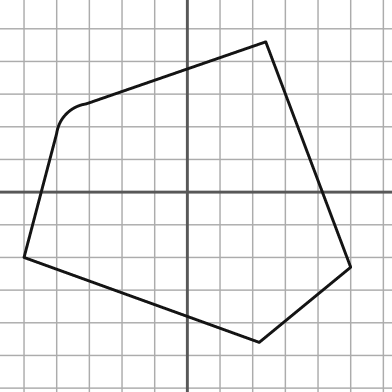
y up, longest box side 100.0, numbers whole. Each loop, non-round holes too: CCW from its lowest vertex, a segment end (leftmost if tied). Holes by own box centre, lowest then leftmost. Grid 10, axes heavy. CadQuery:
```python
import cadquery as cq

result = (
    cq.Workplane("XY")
    .moveTo(22.0, -46.0)
    .lineTo(50.0, -23.0)
    .lineTo(24.0, 46.0)
    .lineTo(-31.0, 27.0)
    .threePointArc((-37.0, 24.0), (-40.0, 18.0))
    .lineTo(-50.0, -20.0)
    .close()
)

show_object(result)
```